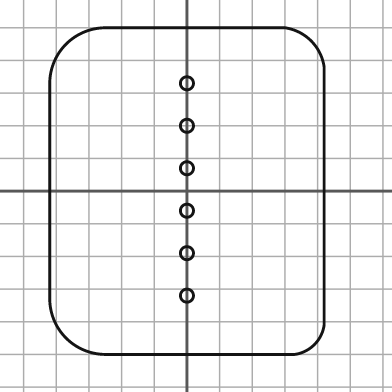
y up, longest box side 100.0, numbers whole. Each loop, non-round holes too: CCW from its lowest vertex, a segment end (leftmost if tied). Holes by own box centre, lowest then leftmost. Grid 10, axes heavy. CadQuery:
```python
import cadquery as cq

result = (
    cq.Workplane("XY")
    .moveTo(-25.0, -50.0)
    .lineTo(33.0, -50.0)
    .threePointArc((39.0, -47.0), (42.0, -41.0))
    .lineTo(42.0, 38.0)
    .threePointArc((38.0, 46.0), (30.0, 50.0))
    .lineTo(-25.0, 50.0)
    .threePointArc((-37.0, 45.0), (-42.0, 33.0))
    .lineTo(-42.0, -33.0)
    .threePointArc((-37.0, -45.0), (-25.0, -50.0))
    .close()
    .moveTo(0.0, -32.0)
    .circle(2.0)
    .moveTo(0.0, -19.0)
    .circle(2.0)
    .moveTo(0.0, -6.0)
    .circle(2.0)
    .moveTo(0.0, 7.0)
    .circle(2.0)
    .moveTo(0.0, 20.0)
    .circle(2.0)
    .moveTo(0.0, 33.0)
    .circle(2.0)
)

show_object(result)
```